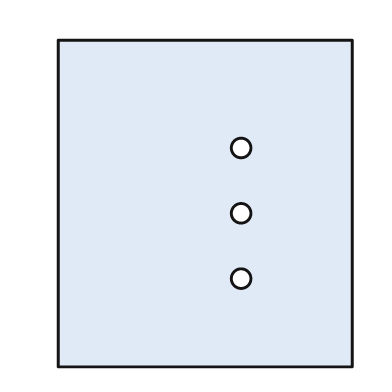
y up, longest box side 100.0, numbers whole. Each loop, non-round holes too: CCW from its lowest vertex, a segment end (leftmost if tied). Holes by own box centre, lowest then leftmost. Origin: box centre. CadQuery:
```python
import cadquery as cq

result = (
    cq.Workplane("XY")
    .moveTo(-45.0, -50.0)
    .lineTo(45.0, -50.0)
    .lineTo(45.0, 50.0)
    .lineTo(-45.0, 50.0)
    .close()
    .moveTo(11.0, -23.0)
    .circle(3.0)
    .moveTo(11.0, -3.0)
    .circle(3.0)
    .moveTo(11.0, 17.0)
    .circle(3.0)
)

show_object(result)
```